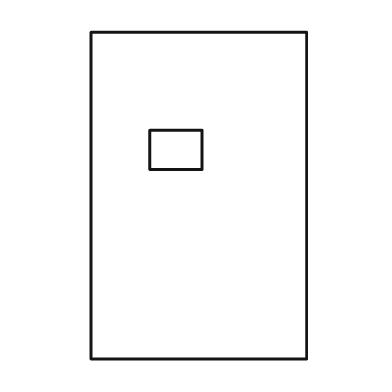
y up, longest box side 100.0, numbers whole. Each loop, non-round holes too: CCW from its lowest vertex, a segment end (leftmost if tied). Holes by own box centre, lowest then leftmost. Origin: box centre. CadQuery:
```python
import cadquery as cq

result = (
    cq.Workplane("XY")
    .moveTo(-33.0, -50.0)
    .lineTo(33.0, -50.0)
    .lineTo(33.0, 50.0)
    .lineTo(-33.0, 50.0)
    .close()
    .moveTo(-15.0, 8.0)
    .lineTo(1.0, 8.0)
    .lineTo(1.0, 20.0)
    .lineTo(-15.0, 20.0)
    .close()
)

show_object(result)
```